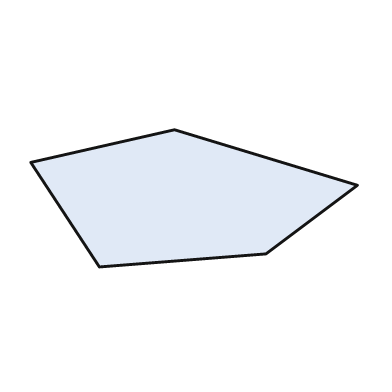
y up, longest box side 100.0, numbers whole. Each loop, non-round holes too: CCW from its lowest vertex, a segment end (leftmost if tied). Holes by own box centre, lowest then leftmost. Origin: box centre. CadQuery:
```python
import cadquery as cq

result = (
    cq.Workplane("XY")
    .moveTo(-29.0, -21.0)
    .lineTo(22.0, -17.0)
    .lineTo(50.0, 4.0)
    .lineTo(-6.0, 21.0)
    .lineTo(-50.0, 11.0)
    .close()
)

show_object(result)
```